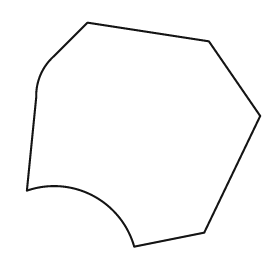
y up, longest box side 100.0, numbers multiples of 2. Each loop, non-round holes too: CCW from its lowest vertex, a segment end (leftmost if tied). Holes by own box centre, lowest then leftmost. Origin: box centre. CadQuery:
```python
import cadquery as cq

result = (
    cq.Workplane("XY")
    .moveTo(-4.0, -48.0)
    .lineTo(26.0, -42.0)
    .lineTo(50.0, 8.0)
    .lineTo(28.0, 40.0)
    .lineTo(-24.0, 48.0)
    .lineTo(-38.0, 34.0)
    .threePointArc((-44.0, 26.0), (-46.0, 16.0))
    .lineTo(-50.0, -24.0)
    .threePointArc((-22.0, -26.0), (-4.0, -48.0))
    .close()
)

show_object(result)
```